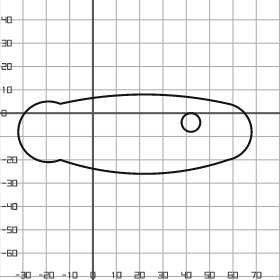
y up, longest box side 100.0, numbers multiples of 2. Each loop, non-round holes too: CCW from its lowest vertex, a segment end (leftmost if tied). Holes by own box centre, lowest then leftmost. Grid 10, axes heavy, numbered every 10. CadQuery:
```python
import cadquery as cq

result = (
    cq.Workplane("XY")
    .moveTo(-14.0, -20.0)
    .threePointArc((22.0, -26.0), (58.0, -20.0))
    .threePointArc((68.0, -8.0), (58.0, 4.0))
    .threePointArc((22.0, 8.0), (-14.0, 4.0))
    .threePointArc((-32.0, -8.0), (-14.0, -20.0))
    .close()
    .moveTo(42.0, -4.0)
    .circle(4.0)
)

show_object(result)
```